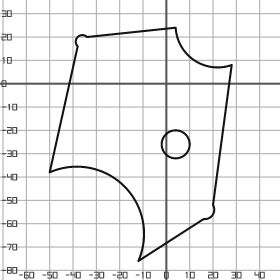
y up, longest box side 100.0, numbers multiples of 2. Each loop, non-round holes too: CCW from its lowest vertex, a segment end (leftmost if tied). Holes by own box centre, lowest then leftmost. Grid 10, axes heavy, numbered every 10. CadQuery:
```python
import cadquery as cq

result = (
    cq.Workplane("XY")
    .moveTo(-12.0, -76.0)
    .lineTo(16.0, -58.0)
    .threePointArc((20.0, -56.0), (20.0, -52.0))
    .lineTo(28.0, 8.0)
    .threePointArc((12.0, 10.0), (4.0, 24.0))
    .lineTo(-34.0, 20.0)
    .threePointArc((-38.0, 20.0), (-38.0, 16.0))
    .lineTo(-50.0, -38.0)
    .threePointArc((-18.0, -44.0), (-12.0, -76.0))
    .close()
    .moveTo(4.0, -26.0)
    .circle(6.0)
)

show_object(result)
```